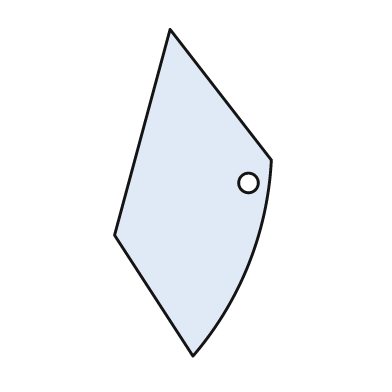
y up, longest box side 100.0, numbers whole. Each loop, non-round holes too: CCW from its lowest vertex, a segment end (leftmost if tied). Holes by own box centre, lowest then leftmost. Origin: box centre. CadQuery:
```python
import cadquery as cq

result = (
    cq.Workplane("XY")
    .moveTo(0.0, -50.0)
    .threePointArc((17.0, -22.0), (24.0, 10.0))
    .lineTo(-7.0, 50.0)
    .lineTo(-24.0, -13.0)
    .close()
    .moveTo(17.0, 3.0)
    .circle(3.0)
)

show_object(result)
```